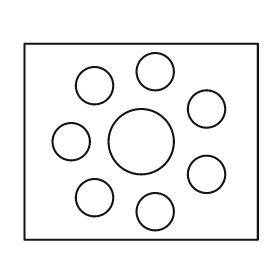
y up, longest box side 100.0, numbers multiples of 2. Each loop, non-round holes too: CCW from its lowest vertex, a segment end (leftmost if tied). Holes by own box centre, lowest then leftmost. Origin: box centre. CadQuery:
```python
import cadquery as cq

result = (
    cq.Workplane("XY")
    .moveTo(-50.0, -42.0)
    .lineTo(50.0, -42.0)
    .lineTo(50.0, 42.0)
    .lineTo(-50.0, 42.0)
    .close()
    .moveTo(6.0, -30.0)
    .circle(8.0)
    .moveTo(-20.0, -24.0)
    .circle(8.0)
    .moveTo(28.0, -14.0)
    .circle(8.0)
    .moveTo(-30.0, 0.0)
    .circle(8.0)
    .moveTo(0.0, 0.0)
    .circle(14.0)
    .moveTo(28.0, 14.0)
    .circle(8.0)
    .moveTo(-20.0, 24.0)
    .circle(8.0)
    .moveTo(6.0, 30.0)
    .circle(8.0)
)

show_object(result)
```